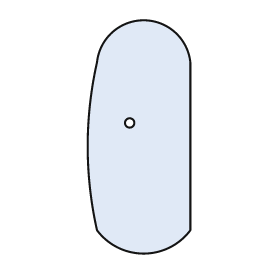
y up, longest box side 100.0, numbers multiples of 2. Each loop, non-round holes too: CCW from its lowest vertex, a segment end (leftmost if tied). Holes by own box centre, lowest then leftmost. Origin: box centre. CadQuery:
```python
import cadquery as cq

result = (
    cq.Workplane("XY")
    .moveTo(-18.0, -40.0)
    .threePointArc((2.0, -50.0), (22.0, -40.0))
    .lineTo(22.0, 32.0)
    .threePointArc((2.0, 50.0), (-18.0, 32.0))
    .threePointArc((-22.0, -4.0), (-18.0, -40.0))
    .close()
    .moveTo(-4.0, 6.0)
    .circle(2.0)
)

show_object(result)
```